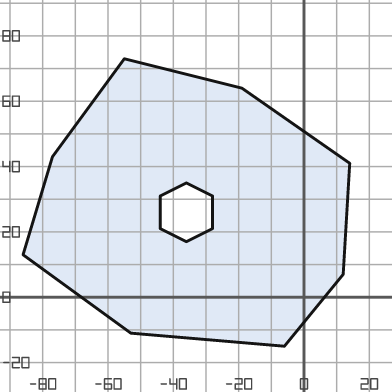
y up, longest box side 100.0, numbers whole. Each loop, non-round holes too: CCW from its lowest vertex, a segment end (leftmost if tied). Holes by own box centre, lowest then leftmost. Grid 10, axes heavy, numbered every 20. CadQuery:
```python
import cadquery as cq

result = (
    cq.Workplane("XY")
    .moveTo(-6.0, -15.0)
    .lineTo(12.0, 7.0)
    .lineTo(14.0, 41.0)
    .lineTo(-19.0, 64.0)
    .lineTo(-55.0, 73.0)
    .lineTo(-77.0, 43.0)
    .lineTo(-86.0, 13.0)
    .lineTo(-53.0, -11.0)
    .close()
    .moveTo(-36.0, 17.0)
    .lineTo(-28.0, 21.0)
    .lineTo(-28.0, 31.0)
    .lineTo(-36.0, 35.0)
    .lineTo(-44.0, 31.0)
    .lineTo(-44.0, 21.0)
    .close()
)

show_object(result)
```